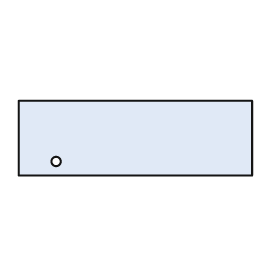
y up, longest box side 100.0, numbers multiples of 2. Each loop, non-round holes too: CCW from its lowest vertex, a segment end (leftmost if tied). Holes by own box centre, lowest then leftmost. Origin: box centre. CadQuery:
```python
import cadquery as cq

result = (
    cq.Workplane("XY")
    .moveTo(-50.0, -16.0)
    .lineTo(50.0, -16.0)
    .lineTo(50.0, 16.0)
    .lineTo(-50.0, 16.0)
    .close()
    .moveTo(-34.0, -10.0)
    .circle(2.0)
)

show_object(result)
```